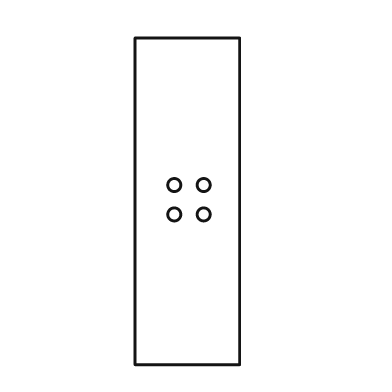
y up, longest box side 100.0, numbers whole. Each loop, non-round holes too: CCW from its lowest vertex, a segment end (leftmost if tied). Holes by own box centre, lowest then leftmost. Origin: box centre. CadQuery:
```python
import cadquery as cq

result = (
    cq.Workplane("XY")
    .moveTo(-16.0, -50.0)
    .lineTo(16.0, -50.0)
    .lineTo(16.0, 50.0)
    .lineTo(-16.0, 50.0)
    .close()
    .moveTo(-4.0, -4.0)
    .circle(2.0)
    .moveTo(5.0, -4.0)
    .circle(2.0)
    .moveTo(-4.0, 5.0)
    .circle(2.0)
    .moveTo(5.0, 5.0)
    .circle(2.0)
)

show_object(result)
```